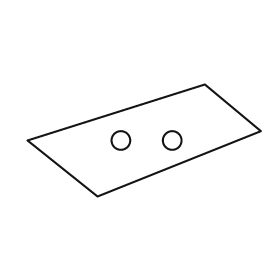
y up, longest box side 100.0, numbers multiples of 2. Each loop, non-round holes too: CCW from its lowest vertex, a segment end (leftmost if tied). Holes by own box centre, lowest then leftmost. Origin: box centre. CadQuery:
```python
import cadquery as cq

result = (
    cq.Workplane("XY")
    .moveTo(-20.0, -24.0)
    .lineTo(50.0, 4.0)
    .lineTo(26.0, 24.0)
    .lineTo(-50.0, 0.0)
    .close()
    .moveTo(-10.0, 0.0)
    .circle(4.0)
    .moveTo(12.0, 0.0)
    .circle(4.0)
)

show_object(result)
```